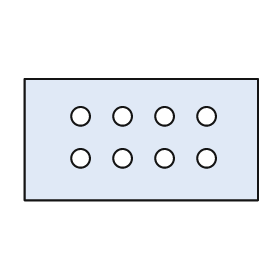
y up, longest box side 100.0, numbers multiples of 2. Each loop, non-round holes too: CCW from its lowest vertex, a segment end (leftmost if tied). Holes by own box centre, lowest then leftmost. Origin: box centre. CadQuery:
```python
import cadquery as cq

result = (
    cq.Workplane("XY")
    .moveTo(-50.0, -26.0)
    .lineTo(50.0, -26.0)
    .lineTo(50.0, 26.0)
    .lineTo(-50.0, 26.0)
    .close()
    .moveTo(-26.0, -8.0)
    .circle(4.0)
    .moveTo(-8.0, -8.0)
    .circle(4.0)
    .moveTo(10.0, -8.0)
    .circle(4.0)
    .moveTo(28.0, -8.0)
    .circle(4.0)
    .moveTo(-26.0, 10.0)
    .circle(4.0)
    .moveTo(-8.0, 10.0)
    .circle(4.0)
    .moveTo(10.0, 10.0)
    .circle(4.0)
    .moveTo(28.0, 10.0)
    .circle(4.0)
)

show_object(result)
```